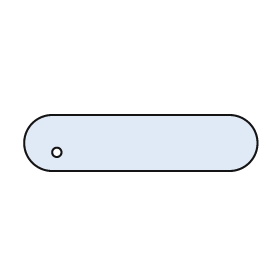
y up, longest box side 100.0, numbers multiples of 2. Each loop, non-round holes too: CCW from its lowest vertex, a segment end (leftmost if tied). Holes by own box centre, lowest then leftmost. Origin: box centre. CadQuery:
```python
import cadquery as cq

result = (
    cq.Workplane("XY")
    .moveTo(-38.0, -12.0)
    .lineTo(38.0, -12.0)
    .threePointArc((50.0, 0.0), (38.0, 12.0))
    .lineTo(-38.0, 12.0)
    .threePointArc((-50.0, 0.0), (-38.0, -12.0))
    .close()
    .moveTo(-36.0, -4.0)
    .circle(2.0)
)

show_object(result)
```